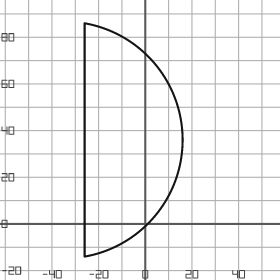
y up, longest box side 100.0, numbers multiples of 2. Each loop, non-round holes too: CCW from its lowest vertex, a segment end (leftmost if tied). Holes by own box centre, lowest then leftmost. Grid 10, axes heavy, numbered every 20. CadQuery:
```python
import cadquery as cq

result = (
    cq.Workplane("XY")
    .moveTo(-26.0, -14.0)
    .threePointArc((16.0, 36.0), (-26.0, 86.0))
    .close()
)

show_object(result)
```